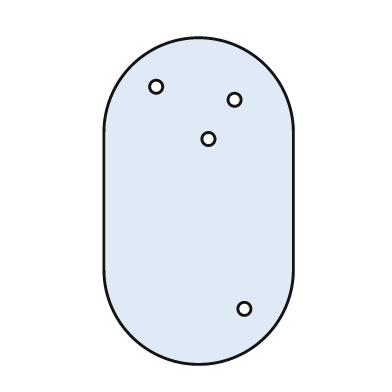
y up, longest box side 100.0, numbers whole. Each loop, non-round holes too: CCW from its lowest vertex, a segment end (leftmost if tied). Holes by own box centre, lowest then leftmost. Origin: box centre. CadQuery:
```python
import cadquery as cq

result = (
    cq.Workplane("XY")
    .moveTo(-29.0, -21.0)
    .threePointArc((0.0, -50.0), (29.0, -21.0))
    .lineTo(29.0, 21.0)
    .threePointArc((0.0, 50.0), (-29.0, 21.0))
    .close()
    .moveTo(14.0, -33.0)
    .circle(2.0)
    .moveTo(3.0, 19.0)
    .circle(2.0)
    .moveTo(11.0, 31.0)
    .circle(2.0)
    .moveTo(-13.0, 35.0)
    .circle(2.0)
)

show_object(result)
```